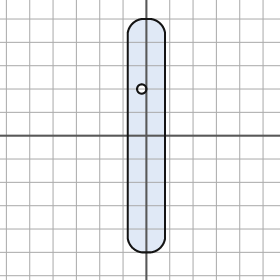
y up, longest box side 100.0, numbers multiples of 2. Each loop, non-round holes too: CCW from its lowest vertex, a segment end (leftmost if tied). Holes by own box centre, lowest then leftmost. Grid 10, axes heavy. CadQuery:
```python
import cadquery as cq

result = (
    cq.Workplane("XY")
    .moveTo(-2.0, -50.0)
    .lineTo(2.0, -50.0)
    .threePointArc((6.0, -48.0), (8.0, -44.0))
    .lineTo(8.0, 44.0)
    .threePointArc((6.0, 48.0), (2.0, 50.0))
    .lineTo(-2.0, 50.0)
    .threePointArc((-6.0, 48.0), (-8.0, 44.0))
    .lineTo(-8.0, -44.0)
    .threePointArc((-6.0, -48.0), (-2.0, -50.0))
    .close()
    .moveTo(-2.0, 20.0)
    .circle(2.0)
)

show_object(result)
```